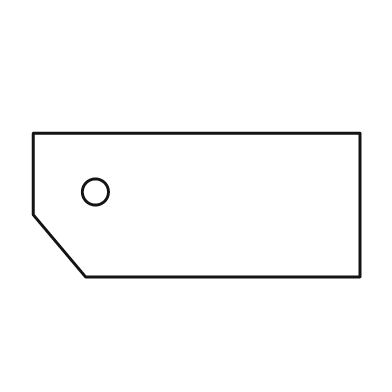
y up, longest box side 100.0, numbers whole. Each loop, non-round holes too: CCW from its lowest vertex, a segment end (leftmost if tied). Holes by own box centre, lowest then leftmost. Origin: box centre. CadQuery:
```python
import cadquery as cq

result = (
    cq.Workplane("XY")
    .moveTo(-34.0, -22.0)
    .lineTo(50.0, -22.0)
    .lineTo(50.0, 22.0)
    .lineTo(-50.0, 22.0)
    .lineTo(-50.0, -3.0)
    .close()
    .moveTo(-31.0, 4.0)
    .circle(4.0)
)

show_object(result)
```